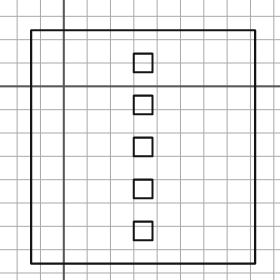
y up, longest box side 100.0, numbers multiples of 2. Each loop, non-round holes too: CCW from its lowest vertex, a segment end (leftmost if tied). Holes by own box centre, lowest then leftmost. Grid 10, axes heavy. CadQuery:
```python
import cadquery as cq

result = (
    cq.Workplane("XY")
    .moveTo(-14.0, -76.0)
    .lineTo(82.0, -76.0)
    .lineTo(82.0, 24.0)
    .lineTo(-14.0, 24.0)
    .close()
    .moveTo(30.0, -66.0)
    .lineTo(38.0, -66.0)
    .lineTo(38.0, -58.0)
    .lineTo(30.0, -58.0)
    .close()
    .moveTo(30.0, -48.0)
    .lineTo(38.0, -48.0)
    .lineTo(38.0, -40.0)
    .lineTo(30.0, -40.0)
    .close()
    .moveTo(30.0, -30.0)
    .lineTo(38.0, -30.0)
    .lineTo(38.0, -22.0)
    .lineTo(30.0, -22.0)
    .close()
    .moveTo(30.0, -12.0)
    .lineTo(38.0, -12.0)
    .lineTo(38.0, -4.0)
    .lineTo(30.0, -4.0)
    .close()
    .moveTo(30.0, 6.0)
    .lineTo(38.0, 6.0)
    .lineTo(38.0, 14.0)
    .lineTo(30.0, 14.0)
    .close()
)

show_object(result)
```